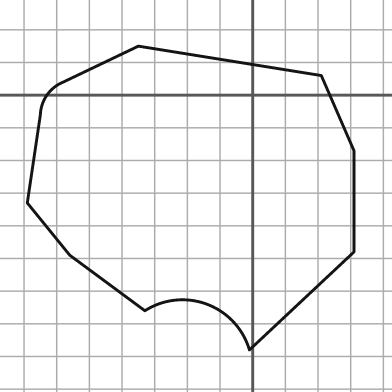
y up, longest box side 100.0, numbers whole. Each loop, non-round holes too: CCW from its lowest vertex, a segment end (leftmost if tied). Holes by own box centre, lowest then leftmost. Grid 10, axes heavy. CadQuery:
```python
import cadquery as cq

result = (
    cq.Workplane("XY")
    .moveTo(-1.0, -78.0)
    .lineTo(31.0, -48.0)
    .lineTo(31.0, -17.0)
    .lineTo(21.0, 6.0)
    .lineTo(-35.0, 15.0)
    .lineTo(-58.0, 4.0)
    .threePointArc((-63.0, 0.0), (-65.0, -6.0))
    .lineTo(-69.0, -33.0)
    .lineTo(-56.0, -49.0)
    .lineTo(-33.0, -66.0)
    .threePointArc((-14.0, -64.0), (-1.0, -78.0))
    .close()
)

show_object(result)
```